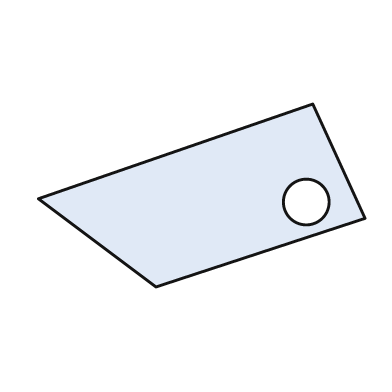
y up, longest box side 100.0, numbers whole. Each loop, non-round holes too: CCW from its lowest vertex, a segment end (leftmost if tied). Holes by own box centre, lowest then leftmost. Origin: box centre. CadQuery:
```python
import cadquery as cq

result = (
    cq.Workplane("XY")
    .moveTo(-14.0, -28.0)
    .lineTo(50.0, -7.0)
    .lineTo(34.0, 28.0)
    .lineTo(-50.0, -1.0)
    .close()
    .moveTo(32.0, -2.0)
    .circle(7.0)
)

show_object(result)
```